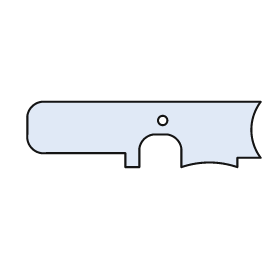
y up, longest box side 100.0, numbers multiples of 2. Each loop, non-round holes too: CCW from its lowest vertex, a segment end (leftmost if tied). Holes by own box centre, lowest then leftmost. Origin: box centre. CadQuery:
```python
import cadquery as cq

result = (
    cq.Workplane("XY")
    .moveTo(-8.0, -14.0)
    .lineTo(-2.0, -14.0)
    .lineTo(-2.0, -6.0)
    .threePointArc((0.0, -2.0), (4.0, 0.0))
    .lineTo(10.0, 0.0)
    .threePointArc((14.0, -2.0), (16.0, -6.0))
    .lineTo(16.0, -14.0)
    .threePointArc((28.0, -12.0), (40.0, -14.0))
    .lineTo(40.0, -10.0)
    .lineTo(50.0, -10.0)
    .threePointArc((46.0, 2.0), (50.0, 14.0))
    .lineTo(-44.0, 14.0)
    .threePointArc((-48.0, 12.0), (-50.0, 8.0))
    .lineTo(-50.0, 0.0)
    .threePointArc((-48.0, -6.0), (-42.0, -8.0))
    .lineTo(-8.0, -8.0)
    .close()
    .moveTo(8.0, 6.0)
    .circle(2.0)
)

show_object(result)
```